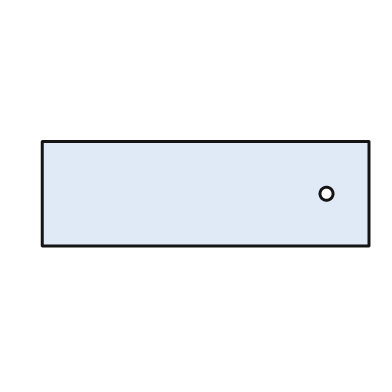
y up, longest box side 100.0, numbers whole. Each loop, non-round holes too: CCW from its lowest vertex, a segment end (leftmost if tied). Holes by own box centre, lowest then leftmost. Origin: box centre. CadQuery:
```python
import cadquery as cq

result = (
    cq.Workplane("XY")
    .moveTo(-50.0, -16.0)
    .lineTo(50.0, -16.0)
    .lineTo(50.0, 16.0)
    .lineTo(-50.0, 16.0)
    .close()
    .moveTo(37.0, 0.0)
    .circle(2.0)
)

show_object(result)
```